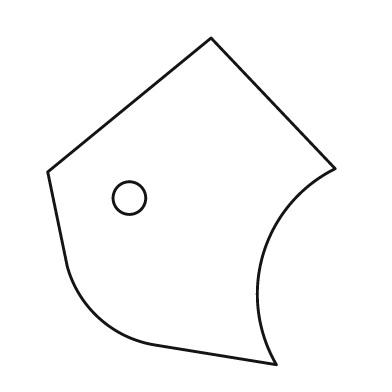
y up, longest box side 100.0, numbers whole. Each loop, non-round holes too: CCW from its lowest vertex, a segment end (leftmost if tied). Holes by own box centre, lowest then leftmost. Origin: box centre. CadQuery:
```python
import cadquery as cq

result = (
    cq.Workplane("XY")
    .moveTo(26.0, -50.0)
    .threePointArc((22.0, -16.0), (44.0, 10.0))
    .lineTo(6.0, 50.0)
    .lineTo(-44.0, 9.0)
    .lineTo(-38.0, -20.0)
    .threePointArc((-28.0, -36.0), (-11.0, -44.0))
    .close()
    .moveTo(-19.0, 1.0)
    .circle(5.0)
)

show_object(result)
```